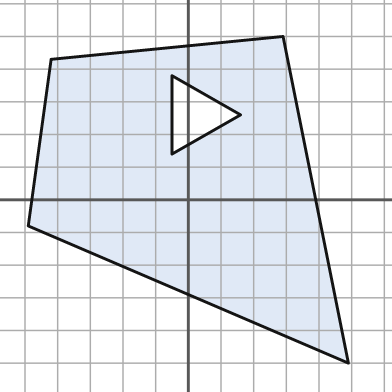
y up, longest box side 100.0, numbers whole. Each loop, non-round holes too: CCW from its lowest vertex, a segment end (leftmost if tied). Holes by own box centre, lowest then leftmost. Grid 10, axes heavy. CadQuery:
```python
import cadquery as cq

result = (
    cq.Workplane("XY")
    .moveTo(49.0, -50.0)
    .lineTo(29.0, 50.0)
    .lineTo(-42.0, 43.0)
    .lineTo(-49.0, -8.0)
    .close()
    .moveTo(-5.0, 14.0)
    .lineTo(16.0, 26.0)
    .lineTo(-5.0, 38.0)
    .close()
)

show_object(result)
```